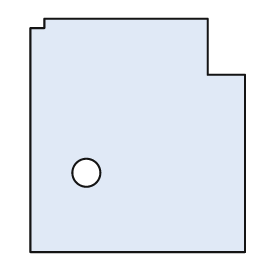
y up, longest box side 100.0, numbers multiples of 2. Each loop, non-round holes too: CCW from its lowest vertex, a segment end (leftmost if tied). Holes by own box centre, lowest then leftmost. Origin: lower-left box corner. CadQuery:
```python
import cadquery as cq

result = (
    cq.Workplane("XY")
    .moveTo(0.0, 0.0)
    .lineTo(92.0, 0.0)
    .lineTo(92.0, 76.0)
    .lineTo(76.0, 76.0)
    .lineTo(76.0, 100.0)
    .lineTo(6.0, 100.0)
    .lineTo(6.0, 96.0)
    .lineTo(0.0, 96.0)
    .close()
    .moveTo(24.0, 34.0)
    .circle(6.0)
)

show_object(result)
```